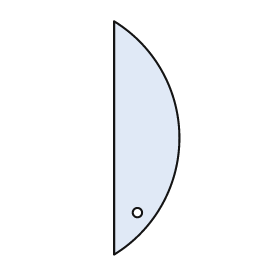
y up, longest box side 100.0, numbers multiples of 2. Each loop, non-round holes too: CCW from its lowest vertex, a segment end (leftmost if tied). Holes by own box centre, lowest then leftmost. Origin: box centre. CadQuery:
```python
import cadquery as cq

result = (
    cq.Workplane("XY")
    .moveTo(-14.0, -50.0)
    .threePointArc((14.0, 0.0), (-14.0, 50.0))
    .close()
    .moveTo(-4.0, -32.0)
    .circle(2.0)
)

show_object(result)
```